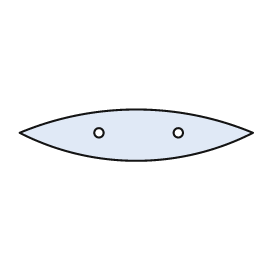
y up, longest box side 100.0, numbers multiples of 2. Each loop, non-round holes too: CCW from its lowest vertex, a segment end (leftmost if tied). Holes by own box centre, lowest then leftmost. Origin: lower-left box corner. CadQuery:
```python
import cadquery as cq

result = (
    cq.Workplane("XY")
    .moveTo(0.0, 12.0)
    .threePointArc((50.0, 0.0), (100.0, 12.0))
    .threePointArc((50.0, 22.0), (0.0, 12.0))
    .close()
    .moveTo(34.0, 12.0)
    .circle(2.0)
    .moveTo(68.0, 12.0)
    .circle(2.0)
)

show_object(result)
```